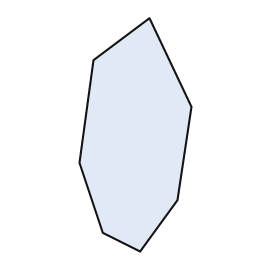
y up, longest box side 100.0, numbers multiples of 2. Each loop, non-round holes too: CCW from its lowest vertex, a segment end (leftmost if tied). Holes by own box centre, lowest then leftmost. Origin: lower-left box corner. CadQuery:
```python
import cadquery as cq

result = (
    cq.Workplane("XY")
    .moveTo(26.0, 0.0)
    .lineTo(42.0, 22.0)
    .lineTo(48.0, 62.0)
    .lineTo(30.0, 100.0)
    .lineTo(6.0, 82.0)
    .lineTo(0.0, 38.0)
    .lineTo(10.0, 8.0)
    .close()
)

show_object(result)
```